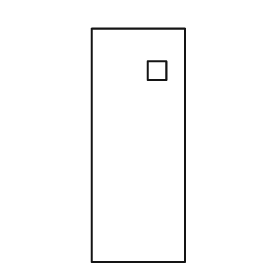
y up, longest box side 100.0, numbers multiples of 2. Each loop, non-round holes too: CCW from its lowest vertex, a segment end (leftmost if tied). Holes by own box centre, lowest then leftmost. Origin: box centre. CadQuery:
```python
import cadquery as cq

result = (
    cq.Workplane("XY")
    .moveTo(-20.0, -50.0)
    .lineTo(20.0, -50.0)
    .lineTo(20.0, 50.0)
    .lineTo(-20.0, 50.0)
    .close()
    .moveTo(4.0, 28.0)
    .lineTo(12.0, 28.0)
    .lineTo(12.0, 36.0)
    .lineTo(4.0, 36.0)
    .close()
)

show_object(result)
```